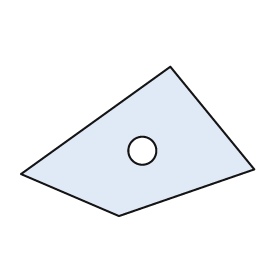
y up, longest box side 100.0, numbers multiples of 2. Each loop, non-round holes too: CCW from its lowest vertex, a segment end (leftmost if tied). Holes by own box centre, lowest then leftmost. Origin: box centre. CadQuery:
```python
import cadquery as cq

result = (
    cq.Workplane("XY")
    .moveTo(-8.0, -32.0)
    .lineTo(50.0, -12.0)
    .lineTo(14.0, 32.0)
    .lineTo(-50.0, -14.0)
    .close()
    .moveTo(2.0, -4.0)
    .circle(6.0)
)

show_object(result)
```